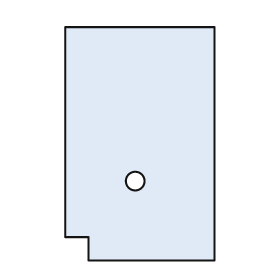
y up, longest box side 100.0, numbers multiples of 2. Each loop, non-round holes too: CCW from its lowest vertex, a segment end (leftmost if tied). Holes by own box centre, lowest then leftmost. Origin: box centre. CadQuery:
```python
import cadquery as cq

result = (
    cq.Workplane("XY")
    .moveTo(-22.0, -50.0)
    .lineTo(32.0, -50.0)
    .lineTo(32.0, 50.0)
    .lineTo(-32.0, 50.0)
    .lineTo(-32.0, -40.0)
    .lineTo(-22.0, -40.0)
    .close()
    .moveTo(-2.0, -16.0)
    .circle(4.0)
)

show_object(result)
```